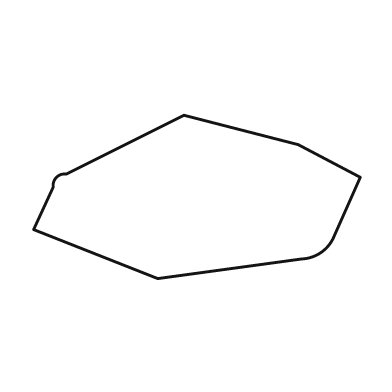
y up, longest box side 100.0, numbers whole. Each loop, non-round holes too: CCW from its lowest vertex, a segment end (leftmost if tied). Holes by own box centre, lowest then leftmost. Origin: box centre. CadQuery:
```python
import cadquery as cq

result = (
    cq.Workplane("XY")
    .moveTo(-12.0, -25.0)
    .lineTo(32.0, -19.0)
    .threePointArc((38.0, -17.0), (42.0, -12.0))
    .lineTo(50.0, 6.0)
    .lineTo(31.0, 16.0)
    .lineTo(-4.0, 25.0)
    .lineTo(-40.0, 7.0)
    .threePointArc((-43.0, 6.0), (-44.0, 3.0))
    .lineTo(-50.0, -10.0)
    .close()
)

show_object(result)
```